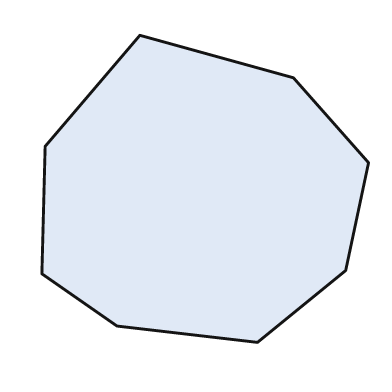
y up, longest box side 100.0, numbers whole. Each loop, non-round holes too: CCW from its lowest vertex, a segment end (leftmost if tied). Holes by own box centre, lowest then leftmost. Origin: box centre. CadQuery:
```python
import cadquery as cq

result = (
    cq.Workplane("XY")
    .moveTo(16.0, -47.0)
    .lineTo(43.0, -25.0)
    .lineTo(50.0, 8.0)
    .lineTo(27.0, 34.0)
    .lineTo(-20.0, 47.0)
    .lineTo(-49.0, 13.0)
    .lineTo(-50.0, -26.0)
    .lineTo(-27.0, -42.0)
    .close()
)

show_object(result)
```